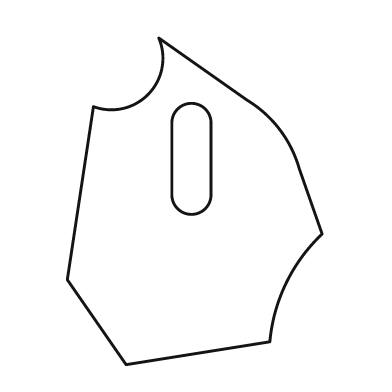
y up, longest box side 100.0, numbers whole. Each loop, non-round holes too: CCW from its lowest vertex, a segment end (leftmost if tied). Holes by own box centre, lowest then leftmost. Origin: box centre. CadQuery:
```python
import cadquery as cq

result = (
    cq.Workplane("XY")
    .moveTo(-21.0, -50.0)
    .lineTo(23.0, -43.0)
    .threePointArc((28.0, -25.0), (39.0, -10.0))
    .lineTo(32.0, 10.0)
    .threePointArc((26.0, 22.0), (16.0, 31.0))
    .lineTo(-11.0, 50.0)
    .threePointArc((-14.0, 33.0), (-31.0, 29.0))
    .lineTo(-39.0, -24.0)
    .close()
    .moveTo(-7.0, 2.0)
    .threePointArc((-1.0, -4.0), (5.0, 2.0))
    .lineTo(5.0, 24.0)
    .threePointArc((-1.0, 30.0), (-7.0, 24.0))
    .close()
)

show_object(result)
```